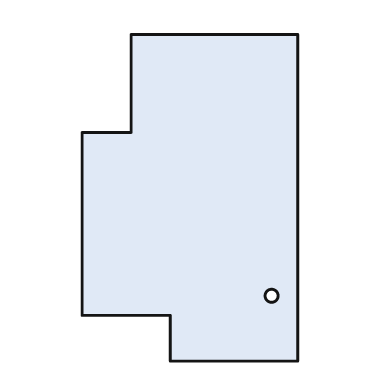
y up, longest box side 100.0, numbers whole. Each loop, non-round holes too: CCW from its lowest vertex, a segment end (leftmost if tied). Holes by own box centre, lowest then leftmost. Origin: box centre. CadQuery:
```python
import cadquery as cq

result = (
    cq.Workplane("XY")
    .moveTo(-6.0, -50.0)
    .lineTo(33.0, -50.0)
    .lineTo(33.0, 50.0)
    .lineTo(-18.0, 50.0)
    .lineTo(-18.0, 20.0)
    .lineTo(-33.0, 20.0)
    .lineTo(-33.0, -36.0)
    .lineTo(-6.0, -36.0)
    .close()
    .moveTo(25.0, -30.0)
    .circle(2.0)
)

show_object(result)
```